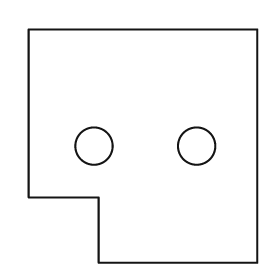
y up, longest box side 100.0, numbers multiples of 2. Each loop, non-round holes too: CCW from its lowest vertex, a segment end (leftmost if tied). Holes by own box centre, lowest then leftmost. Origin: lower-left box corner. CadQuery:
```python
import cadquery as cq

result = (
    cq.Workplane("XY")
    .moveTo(30.0, 0.0)
    .lineTo(98.0, 0.0)
    .lineTo(98.0, 100.0)
    .lineTo(0.0, 100.0)
    .lineTo(0.0, 28.0)
    .lineTo(30.0, 28.0)
    .close()
    .moveTo(28.0, 50.0)
    .circle(8.0)
    .moveTo(72.0, 50.0)
    .circle(8.0)
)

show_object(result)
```